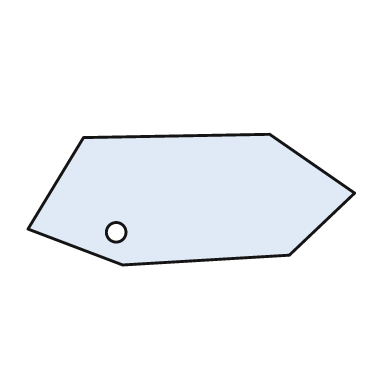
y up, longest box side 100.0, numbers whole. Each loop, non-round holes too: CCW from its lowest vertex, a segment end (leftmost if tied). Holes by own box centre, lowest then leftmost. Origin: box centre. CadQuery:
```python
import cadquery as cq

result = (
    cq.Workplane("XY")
    .moveTo(-21.0, -20.0)
    .lineTo(30.0, -17.0)
    .lineTo(50.0, 2.0)
    .lineTo(24.0, 20.0)
    .lineTo(-33.0, 19.0)
    .lineTo(-50.0, -9.0)
    .close()
    .moveTo(-23.0, -10.0)
    .circle(3.0)
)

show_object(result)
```